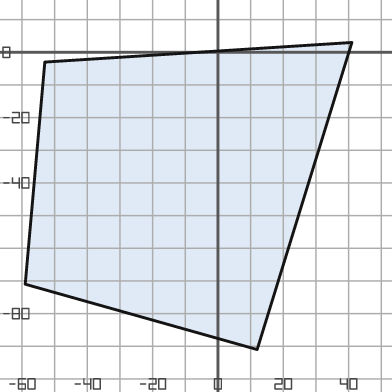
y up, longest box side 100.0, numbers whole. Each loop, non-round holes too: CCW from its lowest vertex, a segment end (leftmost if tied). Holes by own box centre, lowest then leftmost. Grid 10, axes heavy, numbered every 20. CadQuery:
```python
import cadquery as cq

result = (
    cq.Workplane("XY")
    .moveTo(12.0, -91.0)
    .lineTo(41.0, 3.0)
    .lineTo(-53.0, -3.0)
    .lineTo(-59.0, -71.0)
    .close()
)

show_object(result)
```